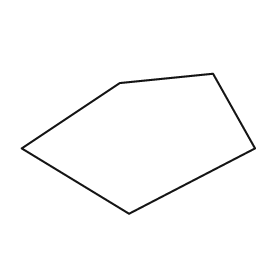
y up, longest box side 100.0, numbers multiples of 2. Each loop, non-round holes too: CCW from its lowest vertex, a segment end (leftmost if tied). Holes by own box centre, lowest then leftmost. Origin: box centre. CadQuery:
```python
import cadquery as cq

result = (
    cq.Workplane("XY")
    .moveTo(-4.0, -30.0)
    .lineTo(50.0, -2.0)
    .lineTo(32.0, 30.0)
    .lineTo(-8.0, 26.0)
    .lineTo(-50.0, -2.0)
    .close()
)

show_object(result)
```